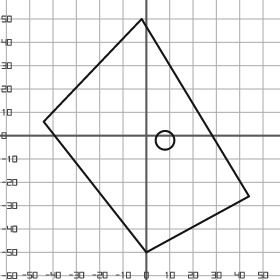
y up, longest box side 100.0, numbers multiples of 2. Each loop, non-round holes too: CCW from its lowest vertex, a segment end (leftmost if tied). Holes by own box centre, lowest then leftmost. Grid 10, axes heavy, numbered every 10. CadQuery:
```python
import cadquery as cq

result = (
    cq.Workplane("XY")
    .moveTo(0.0, -50.0)
    .lineTo(44.0, -26.0)
    .lineTo(-2.0, 50.0)
    .lineTo(-44.0, 6.0)
    .close()
    .moveTo(8.0, -2.0)
    .circle(4.0)
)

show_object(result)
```